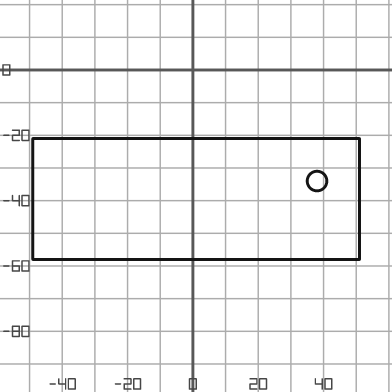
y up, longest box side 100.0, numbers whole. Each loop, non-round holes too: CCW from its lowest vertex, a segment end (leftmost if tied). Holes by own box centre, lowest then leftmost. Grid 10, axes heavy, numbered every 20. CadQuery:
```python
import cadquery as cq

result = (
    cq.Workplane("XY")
    .moveTo(-49.0, -58.0)
    .lineTo(51.0, -58.0)
    .lineTo(51.0, -21.0)
    .lineTo(-49.0, -21.0)
    .close()
    .moveTo(38.0, -34.0)
    .circle(3.0)
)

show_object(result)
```